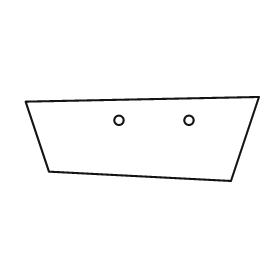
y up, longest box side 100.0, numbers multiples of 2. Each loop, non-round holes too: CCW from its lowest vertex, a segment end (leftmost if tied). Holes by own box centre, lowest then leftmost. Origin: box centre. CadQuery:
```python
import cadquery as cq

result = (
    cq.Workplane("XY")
    .moveTo(38.0, -18.0)
    .lineTo(50.0, 18.0)
    .lineTo(-50.0, 16.0)
    .lineTo(-40.0, -14.0)
    .close()
    .moveTo(-10.0, 8.0)
    .circle(2.0)
    .moveTo(20.0, 8.0)
    .circle(2.0)
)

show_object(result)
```